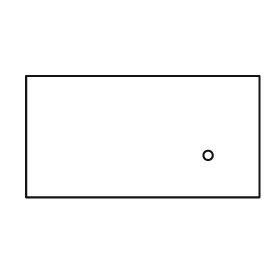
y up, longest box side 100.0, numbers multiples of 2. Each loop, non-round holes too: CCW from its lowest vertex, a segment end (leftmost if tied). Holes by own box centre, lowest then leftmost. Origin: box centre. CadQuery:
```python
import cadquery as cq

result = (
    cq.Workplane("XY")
    .moveTo(-50.0, -26.0)
    .lineTo(50.0, -26.0)
    .lineTo(50.0, 26.0)
    .lineTo(-50.0, 26.0)
    .close()
    .moveTo(28.0, -8.0)
    .circle(2.0)
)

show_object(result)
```